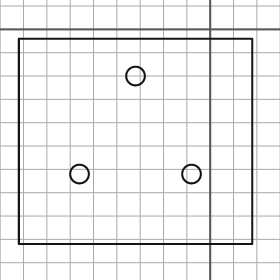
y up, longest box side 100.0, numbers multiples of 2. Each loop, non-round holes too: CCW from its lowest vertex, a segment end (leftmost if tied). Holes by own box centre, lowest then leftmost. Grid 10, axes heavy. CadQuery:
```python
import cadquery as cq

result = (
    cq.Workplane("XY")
    .moveTo(-82.0, -92.0)
    .lineTo(18.0, -92.0)
    .lineTo(18.0, -4.0)
    .lineTo(-82.0, -4.0)
    .close()
    .moveTo(-56.0, -62.0)
    .circle(4.0)
    .moveTo(-8.0, -62.0)
    .circle(4.0)
    .moveTo(-32.0, -20.0)
    .circle(4.0)
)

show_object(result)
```